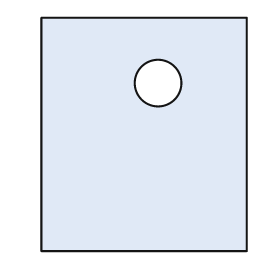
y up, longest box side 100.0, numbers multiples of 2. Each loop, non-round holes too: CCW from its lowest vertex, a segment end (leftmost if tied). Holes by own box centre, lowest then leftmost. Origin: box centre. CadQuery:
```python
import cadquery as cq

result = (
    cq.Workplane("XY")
    .moveTo(-44.0, -50.0)
    .lineTo(44.0, -50.0)
    .lineTo(44.0, 50.0)
    .lineTo(-44.0, 50.0)
    .close()
    .moveTo(6.0, 22.0)
    .circle(10.0)
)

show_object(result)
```